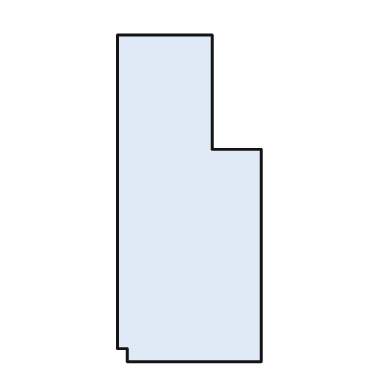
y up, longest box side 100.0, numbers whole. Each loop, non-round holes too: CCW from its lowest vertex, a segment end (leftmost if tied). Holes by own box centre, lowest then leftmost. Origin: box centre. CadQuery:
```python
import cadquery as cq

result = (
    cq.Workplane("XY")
    .moveTo(-19.0, -50.0)
    .lineTo(22.0, -50.0)
    .lineTo(22.0, 15.0)
    .lineTo(7.0, 15.0)
    .lineTo(7.0, 50.0)
    .lineTo(-22.0, 50.0)
    .lineTo(-22.0, -46.0)
    .lineTo(-19.0, -46.0)
    .close()
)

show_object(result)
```